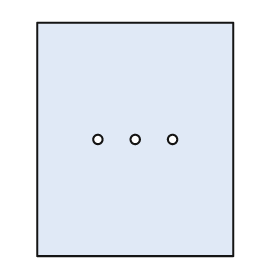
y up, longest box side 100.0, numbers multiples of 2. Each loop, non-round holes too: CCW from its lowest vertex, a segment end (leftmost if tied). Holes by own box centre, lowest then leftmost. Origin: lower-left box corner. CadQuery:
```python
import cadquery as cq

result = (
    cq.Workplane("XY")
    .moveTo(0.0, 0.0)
    .lineTo(84.0, 0.0)
    .lineTo(84.0, 100.0)
    .lineTo(0.0, 100.0)
    .close()
    .moveTo(26.0, 50.0)
    .circle(2.0)
    .moveTo(42.0, 50.0)
    .circle(2.0)
    .moveTo(58.0, 50.0)
    .circle(2.0)
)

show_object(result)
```